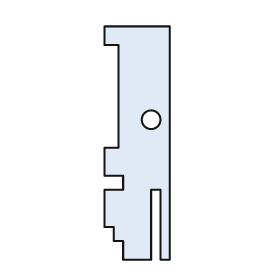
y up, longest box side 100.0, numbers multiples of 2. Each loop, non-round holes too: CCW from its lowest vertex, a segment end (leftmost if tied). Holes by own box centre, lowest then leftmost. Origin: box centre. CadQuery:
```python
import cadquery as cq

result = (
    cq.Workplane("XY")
    .moveTo(-6.0, -50.0)
    .lineTo(6.0, -50.0)
    .lineTo(6.0, -20.0)
    .lineTo(10.0, -20.0)
    .lineTo(10.0, -50.0)
    .lineTo(14.0, -50.0)
    .lineTo(14.0, 50.0)
    .lineTo(-14.0, 50.0)
    .lineTo(-14.0, 42.0)
    .lineTo(-8.0, 42.0)
    .lineTo(-8.0, -2.0)
    .lineTo(-14.0, -2.0)
    .lineTo(-14.0, -14.0)
    .lineTo(-6.0, -14.0)
    .lineTo(-6.0, -20.0)
    .lineTo(-14.0, -20.0)
    .lineTo(-14.0, -36.0)
    .lineTo(-10.0, -36.0)
    .lineTo(-10.0, -42.0)
    .lineTo(-6.0, -42.0)
    .close()
    .moveTo(6.0, 10.0)
    .circle(4.0)
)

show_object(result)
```